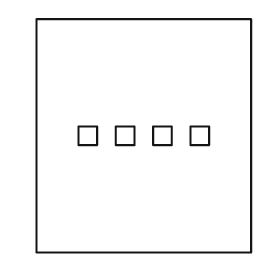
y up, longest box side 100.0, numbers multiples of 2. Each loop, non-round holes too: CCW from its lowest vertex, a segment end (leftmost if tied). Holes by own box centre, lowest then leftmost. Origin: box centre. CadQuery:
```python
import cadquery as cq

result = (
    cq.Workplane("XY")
    .moveTo(-46.0, -50.0)
    .lineTo(46.0, -50.0)
    .lineTo(46.0, 50.0)
    .lineTo(-46.0, 50.0)
    .close()
    .moveTo(-28.0, -4.0)
    .lineTo(-20.0, -4.0)
    .lineTo(-20.0, 4.0)
    .lineTo(-28.0, 4.0)
    .close()
    .moveTo(-12.0, -4.0)
    .lineTo(-4.0, -4.0)
    .lineTo(-4.0, 4.0)
    .lineTo(-12.0, 4.0)
    .close()
    .moveTo(4.0, -4.0)
    .lineTo(12.0, -4.0)
    .lineTo(12.0, 4.0)
    .lineTo(4.0, 4.0)
    .close()
    .moveTo(20.0, -4.0)
    .lineTo(28.0, -4.0)
    .lineTo(28.0, 4.0)
    .lineTo(20.0, 4.0)
    .close()
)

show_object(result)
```